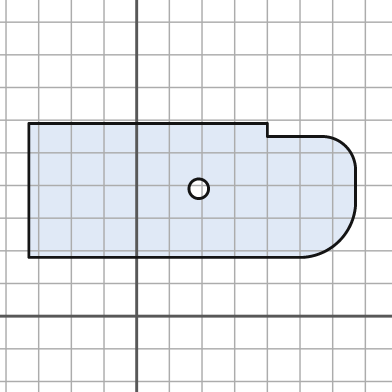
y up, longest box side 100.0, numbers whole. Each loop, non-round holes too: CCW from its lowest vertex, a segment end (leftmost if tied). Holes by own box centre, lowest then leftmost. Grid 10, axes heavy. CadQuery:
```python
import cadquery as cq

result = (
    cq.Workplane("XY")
    .moveTo(-33.0, 18.0)
    .lineTo(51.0, 18.0)
    .threePointArc((62.0, 23.0), (67.0, 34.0))
    .lineTo(67.0, 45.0)
    .threePointArc((64.0, 52.0), (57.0, 55.0))
    .lineTo(40.0, 55.0)
    .lineTo(40.0, 59.0)
    .lineTo(-33.0, 59.0)
    .close()
    .moveTo(19.0, 39.0)
    .circle(3.0)
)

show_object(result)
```